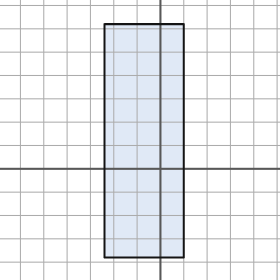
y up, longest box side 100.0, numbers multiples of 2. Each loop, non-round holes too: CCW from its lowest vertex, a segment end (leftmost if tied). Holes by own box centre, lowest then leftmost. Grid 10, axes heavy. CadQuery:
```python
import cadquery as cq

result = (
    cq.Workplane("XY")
    .moveTo(-24.0, -38.0)
    .lineTo(10.0, -38.0)
    .lineTo(10.0, 62.0)
    .lineTo(-24.0, 62.0)
    .close()
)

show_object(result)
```